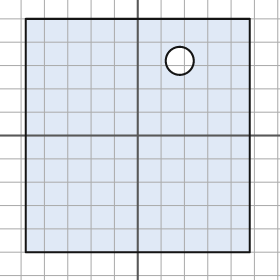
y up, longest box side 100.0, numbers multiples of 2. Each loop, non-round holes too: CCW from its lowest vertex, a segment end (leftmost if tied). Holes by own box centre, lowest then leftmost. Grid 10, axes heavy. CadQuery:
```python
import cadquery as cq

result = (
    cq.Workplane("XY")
    .moveTo(-48.0, -50.0)
    .lineTo(48.0, -50.0)
    .lineTo(48.0, 50.0)
    .lineTo(-48.0, 50.0)
    .close()
    .moveTo(18.0, 32.0)
    .circle(6.0)
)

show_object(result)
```